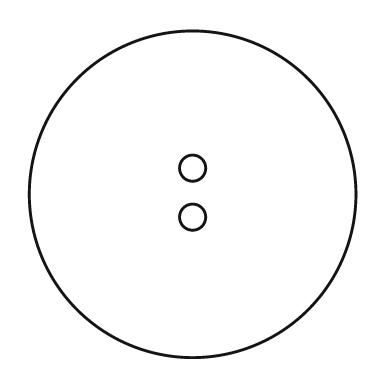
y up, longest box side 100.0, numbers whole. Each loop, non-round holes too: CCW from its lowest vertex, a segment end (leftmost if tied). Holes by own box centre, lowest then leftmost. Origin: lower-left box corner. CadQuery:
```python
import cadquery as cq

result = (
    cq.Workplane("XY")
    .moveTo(50.0, 50.0)
    .circle(50.0)
    .moveTo(50.0, 43.0)
    .circle(4.0)
    .moveTo(50.0, 58.0)
    .circle(4.0)
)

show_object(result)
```